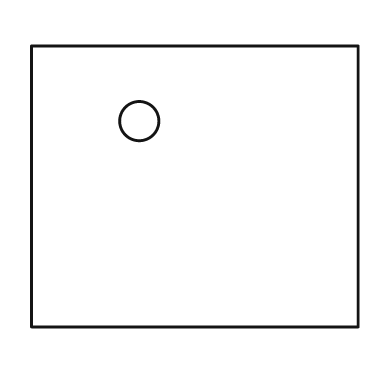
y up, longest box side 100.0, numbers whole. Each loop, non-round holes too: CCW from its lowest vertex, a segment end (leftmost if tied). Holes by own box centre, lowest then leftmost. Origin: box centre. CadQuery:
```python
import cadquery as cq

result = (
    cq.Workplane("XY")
    .moveTo(-50.0, -43.0)
    .lineTo(50.0, -43.0)
    .lineTo(50.0, 43.0)
    .lineTo(-50.0, 43.0)
    .close()
    .moveTo(-17.0, 20.0)
    .circle(6.0)
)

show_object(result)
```